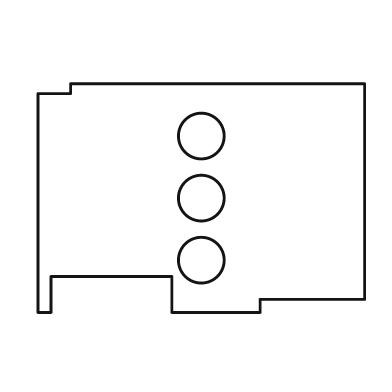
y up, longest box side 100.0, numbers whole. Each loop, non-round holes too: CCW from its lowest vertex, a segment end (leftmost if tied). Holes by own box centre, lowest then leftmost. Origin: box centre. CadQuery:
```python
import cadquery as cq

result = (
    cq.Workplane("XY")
    .moveTo(-50.0, -35.0)
    .lineTo(-46.0, -35.0)
    .lineTo(-46.0, -24.0)
    .lineTo(-9.0, -24.0)
    .lineTo(-9.0, -35.0)
    .lineTo(18.0, -35.0)
    .lineTo(18.0, -31.0)
    .lineTo(50.0, -31.0)
    .lineTo(50.0, 35.0)
    .lineTo(-40.0, 35.0)
    .lineTo(-40.0, 32.0)
    .lineTo(-50.0, 32.0)
    .close()
    .moveTo(0.0, -19.0)
    .circle(7.0)
    .moveTo(0.0, 0.0)
    .circle(7.0)
    .moveTo(0.0, 19.0)
    .circle(7.0)
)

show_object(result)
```